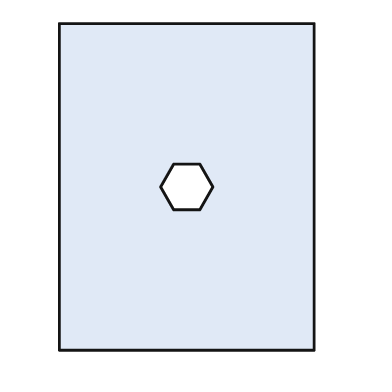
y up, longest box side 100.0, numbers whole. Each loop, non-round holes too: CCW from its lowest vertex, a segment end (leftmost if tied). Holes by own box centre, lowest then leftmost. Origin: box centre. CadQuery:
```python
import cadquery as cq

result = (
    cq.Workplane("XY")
    .moveTo(-39.0, -50.0)
    .lineTo(39.0, -50.0)
    .lineTo(39.0, 50.0)
    .lineTo(-39.0, 50.0)
    .close()
    .moveTo(-4.0, -7.0)
    .lineTo(4.0, -7.0)
    .lineTo(8.0, 0.0)
    .lineTo(4.0, 7.0)
    .lineTo(-4.0, 7.0)
    .lineTo(-8.0, 0.0)
    .close()
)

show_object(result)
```